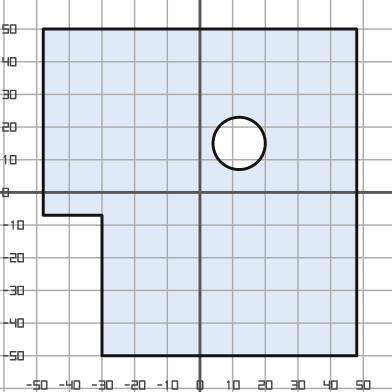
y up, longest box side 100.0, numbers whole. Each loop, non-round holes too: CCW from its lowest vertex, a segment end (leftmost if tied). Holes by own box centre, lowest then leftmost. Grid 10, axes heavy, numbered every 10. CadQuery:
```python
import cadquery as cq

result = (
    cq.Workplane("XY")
    .moveTo(-30.0, -50.0)
    .lineTo(48.0, -50.0)
    .lineTo(48.0, 50.0)
    .lineTo(-48.0, 50.0)
    .lineTo(-48.0, -7.0)
    .lineTo(-30.0, -7.0)
    .close()
    .moveTo(12.0, 15.0)
    .circle(8.0)
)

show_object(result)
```